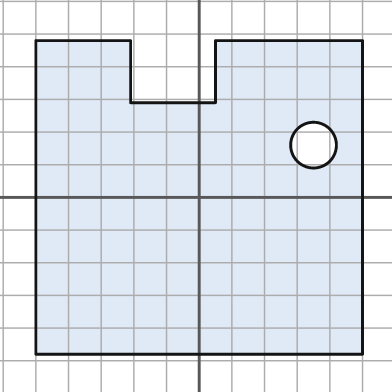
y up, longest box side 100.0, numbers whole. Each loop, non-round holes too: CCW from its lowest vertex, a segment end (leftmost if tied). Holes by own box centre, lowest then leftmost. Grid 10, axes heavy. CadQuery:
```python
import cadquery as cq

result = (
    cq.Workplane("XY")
    .moveTo(-50.0, -48.0)
    .lineTo(50.0, -48.0)
    .lineTo(50.0, 48.0)
    .lineTo(5.0, 48.0)
    .lineTo(5.0, 29.0)
    .lineTo(-21.0, 29.0)
    .lineTo(-21.0, 48.0)
    .lineTo(-50.0, 48.0)
    .close()
    .moveTo(35.0, 16.0)
    .circle(7.0)
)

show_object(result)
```